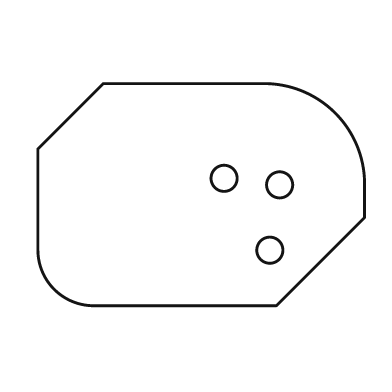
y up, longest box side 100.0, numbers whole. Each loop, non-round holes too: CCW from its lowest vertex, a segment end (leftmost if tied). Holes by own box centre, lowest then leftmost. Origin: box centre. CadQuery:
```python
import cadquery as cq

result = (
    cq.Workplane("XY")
    .moveTo(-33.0, -34.0)
    .lineTo(23.0, -34.0)
    .lineTo(50.0, -7.0)
    .lineTo(50.0, 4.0)
    .threePointArc((41.0, 25.0), (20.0, 34.0))
    .lineTo(-30.0, 34.0)
    .lineTo(-50.0, 14.0)
    .lineTo(-50.0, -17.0)
    .threePointArc((-45.0, -29.0), (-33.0, -34.0))
    .close()
    .moveTo(21.0, -17.0)
    .circle(4.0)
    .moveTo(24.0, 3.0)
    .circle(4.0)
    .moveTo(7.0, 5.0)
    .circle(4.0)
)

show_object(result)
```